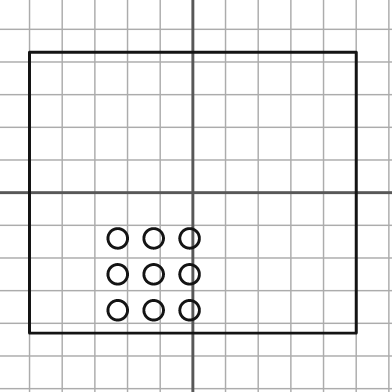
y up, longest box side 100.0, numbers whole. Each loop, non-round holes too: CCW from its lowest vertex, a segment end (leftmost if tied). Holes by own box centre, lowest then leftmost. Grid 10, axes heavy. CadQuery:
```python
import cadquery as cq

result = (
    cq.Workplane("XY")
    .moveTo(-50.0, -43.0)
    .lineTo(50.0, -43.0)
    .lineTo(50.0, 43.0)
    .lineTo(-50.0, 43.0)
    .close()
    .moveTo(-23.0, -36.0)
    .circle(3.0)
    .moveTo(-12.0, -36.0)
    .circle(3.0)
    .moveTo(-1.0, -36.0)
    .circle(3.0)
    .moveTo(-23.0, -25.0)
    .circle(3.0)
    .moveTo(-12.0, -25.0)
    .circle(3.0)
    .moveTo(-1.0, -25.0)
    .circle(3.0)
    .moveTo(-23.0, -14.0)
    .circle(3.0)
    .moveTo(-12.0, -14.0)
    .circle(3.0)
    .moveTo(-1.0, -14.0)
    .circle(3.0)
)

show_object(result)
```